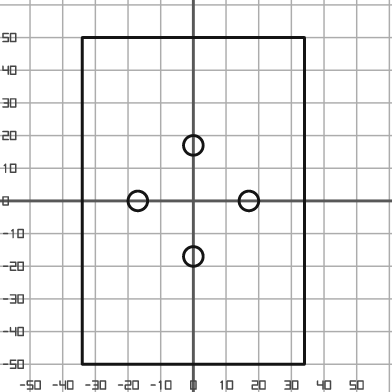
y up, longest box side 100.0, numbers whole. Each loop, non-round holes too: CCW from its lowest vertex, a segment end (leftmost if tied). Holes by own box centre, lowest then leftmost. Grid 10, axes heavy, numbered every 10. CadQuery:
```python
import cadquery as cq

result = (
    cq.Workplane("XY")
    .moveTo(-34.0, -50.0)
    .lineTo(34.0, -50.0)
    .lineTo(34.0, 50.0)
    .lineTo(-34.0, 50.0)
    .close()
    .moveTo(0.0, -17.0)
    .circle(3.0)
    .moveTo(-17.0, 0.0)
    .circle(3.0)
    .moveTo(17.0, 0.0)
    .circle(3.0)
    .moveTo(0.0, 17.0)
    .circle(3.0)
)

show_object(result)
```